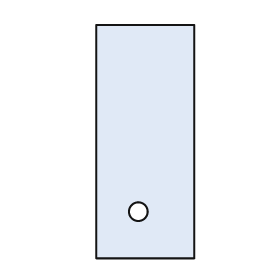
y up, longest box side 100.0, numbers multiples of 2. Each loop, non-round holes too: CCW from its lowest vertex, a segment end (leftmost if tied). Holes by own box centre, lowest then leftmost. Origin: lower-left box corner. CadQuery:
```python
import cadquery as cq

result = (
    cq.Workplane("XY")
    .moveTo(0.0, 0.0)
    .lineTo(42.0, 0.0)
    .lineTo(42.0, 100.0)
    .lineTo(0.0, 100.0)
    .close()
    .moveTo(18.0, 20.0)
    .circle(4.0)
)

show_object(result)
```